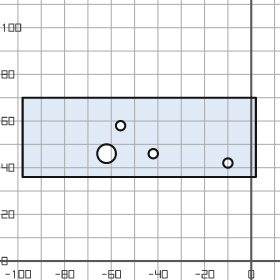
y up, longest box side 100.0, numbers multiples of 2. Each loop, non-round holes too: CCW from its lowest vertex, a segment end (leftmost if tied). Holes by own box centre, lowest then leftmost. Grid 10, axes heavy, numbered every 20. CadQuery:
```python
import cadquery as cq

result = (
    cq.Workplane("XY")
    .moveTo(-98.0, 36.0)
    .lineTo(2.0, 36.0)
    .lineTo(2.0, 70.0)
    .lineTo(-98.0, 70.0)
    .close()
    .moveTo(-10.0, 42.0)
    .circle(2.0)
    .moveTo(-62.0, 46.0)
    .circle(4.0)
    .moveTo(-42.0, 46.0)
    .circle(2.0)
    .moveTo(-56.0, 58.0)
    .circle(2.0)
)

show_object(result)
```